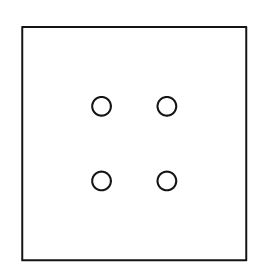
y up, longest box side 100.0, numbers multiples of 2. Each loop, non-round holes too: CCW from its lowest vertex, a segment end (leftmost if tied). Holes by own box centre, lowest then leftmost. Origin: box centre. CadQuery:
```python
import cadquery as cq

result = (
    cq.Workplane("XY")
    .moveTo(-48.0, -50.0)
    .lineTo(48.0, -50.0)
    .lineTo(48.0, 50.0)
    .lineTo(-48.0, 50.0)
    .close()
    .moveTo(-14.0, -16.0)
    .circle(4.0)
    .moveTo(14.0, -16.0)
    .circle(4.0)
    .moveTo(-14.0, 16.0)
    .circle(4.0)
    .moveTo(14.0, 16.0)
    .circle(4.0)
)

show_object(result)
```